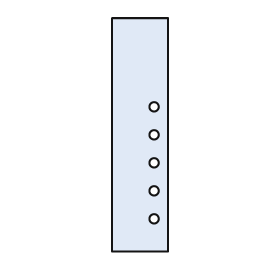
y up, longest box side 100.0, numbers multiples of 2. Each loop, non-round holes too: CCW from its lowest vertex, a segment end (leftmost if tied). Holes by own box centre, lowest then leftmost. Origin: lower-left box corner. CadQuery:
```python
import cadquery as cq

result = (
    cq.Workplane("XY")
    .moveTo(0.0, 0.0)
    .lineTo(24.0, 0.0)
    .lineTo(24.0, 100.0)
    .lineTo(0.0, 100.0)
    .close()
    .moveTo(18.0, 14.0)
    .circle(2.0)
    .moveTo(18.0, 26.0)
    .circle(2.0)
    .moveTo(18.0, 38.0)
    .circle(2.0)
    .moveTo(18.0, 50.0)
    .circle(2.0)
    .moveTo(18.0, 62.0)
    .circle(2.0)
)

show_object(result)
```